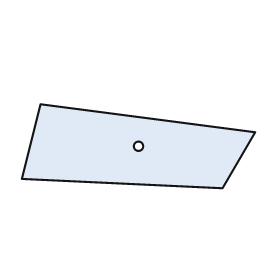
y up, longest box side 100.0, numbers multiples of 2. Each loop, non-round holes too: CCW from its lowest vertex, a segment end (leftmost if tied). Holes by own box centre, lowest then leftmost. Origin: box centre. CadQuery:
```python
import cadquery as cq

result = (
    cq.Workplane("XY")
    .moveTo(36.0, -18.0)
    .lineTo(50.0, 6.0)
    .lineTo(-42.0, 18.0)
    .lineTo(-50.0, -14.0)
    .close()
    .moveTo(0.0, 0.0)
    .circle(2.0)
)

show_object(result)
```